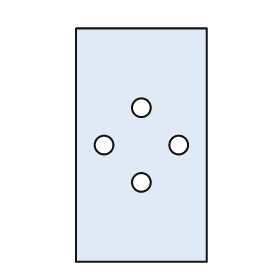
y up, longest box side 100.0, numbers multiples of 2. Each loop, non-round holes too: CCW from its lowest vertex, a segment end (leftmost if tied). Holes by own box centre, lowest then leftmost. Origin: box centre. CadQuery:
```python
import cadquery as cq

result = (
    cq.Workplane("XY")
    .moveTo(-28.0, -50.0)
    .lineTo(28.0, -50.0)
    .lineTo(28.0, 50.0)
    .lineTo(-28.0, 50.0)
    .close()
    .moveTo(0.0, -16.0)
    .circle(4.0)
    .moveTo(-16.0, 0.0)
    .circle(4.0)
    .moveTo(16.0, 0.0)
    .circle(4.0)
    .moveTo(0.0, 16.0)
    .circle(4.0)
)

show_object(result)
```